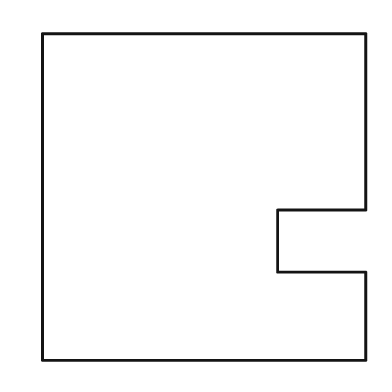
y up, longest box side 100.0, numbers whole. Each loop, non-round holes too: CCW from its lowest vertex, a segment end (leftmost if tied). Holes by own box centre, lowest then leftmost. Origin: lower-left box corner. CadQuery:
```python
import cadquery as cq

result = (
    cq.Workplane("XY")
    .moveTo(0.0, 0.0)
    .lineTo(99.0, 0.0)
    .lineTo(99.0, 27.0)
    .lineTo(72.0, 27.0)
    .lineTo(72.0, 46.0)
    .lineTo(99.0, 46.0)
    .lineTo(99.0, 100.0)
    .lineTo(0.0, 100.0)
    .close()
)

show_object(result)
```